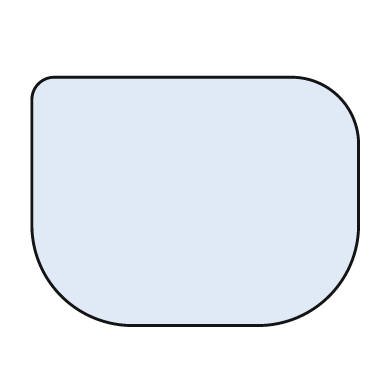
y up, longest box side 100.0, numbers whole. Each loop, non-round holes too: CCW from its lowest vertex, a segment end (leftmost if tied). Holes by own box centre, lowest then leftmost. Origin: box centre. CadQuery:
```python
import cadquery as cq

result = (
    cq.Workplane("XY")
    .moveTo(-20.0, -38.0)
    .lineTo(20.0, -38.0)
    .threePointArc((41.0, -29.0), (50.0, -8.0))
    .lineTo(50.0, 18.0)
    .threePointArc((44.0, 32.0), (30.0, 38.0))
    .lineTo(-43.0, 38.0)
    .threePointArc((-48.0, 36.0), (-50.0, 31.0))
    .lineTo(-50.0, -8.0)
    .threePointArc((-41.0, -29.0), (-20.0, -38.0))
    .close()
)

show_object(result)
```